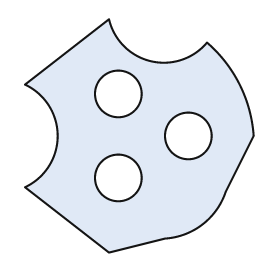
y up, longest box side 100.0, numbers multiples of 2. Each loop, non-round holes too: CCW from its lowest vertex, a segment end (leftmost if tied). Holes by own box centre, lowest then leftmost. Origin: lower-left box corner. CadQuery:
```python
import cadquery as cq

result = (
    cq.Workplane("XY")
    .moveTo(36.0, 0.0)
    .lineTo(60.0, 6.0)
    .threePointArc((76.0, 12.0), (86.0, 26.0))
    .lineTo(98.0, 50.0)
    .threePointArc((92.0, 72.0), (78.0, 90.0))
    .threePointArc((54.0, 82.0), (36.0, 100.0))
    .lineTo(0.0, 72.0)
    .threePointArc((14.0, 50.0), (0.0, 28.0))
    .close()
    .moveTo(40.0, 32.0)
    .circle(10.0)
    .moveTo(70.0, 50.0)
    .circle(10.0)
    .moveTo(40.0, 68.0)
    .circle(10.0)
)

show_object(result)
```